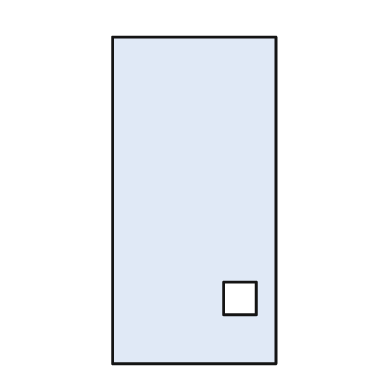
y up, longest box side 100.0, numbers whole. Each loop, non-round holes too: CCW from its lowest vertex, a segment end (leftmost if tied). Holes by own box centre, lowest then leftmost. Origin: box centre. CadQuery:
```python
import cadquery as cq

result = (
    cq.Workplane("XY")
    .moveTo(-25.0, -50.0)
    .lineTo(25.0, -50.0)
    .lineTo(25.0, 50.0)
    .lineTo(-25.0, 50.0)
    .close()
    .moveTo(9.0, -35.0)
    .lineTo(19.0, -35.0)
    .lineTo(19.0, -25.0)
    .lineTo(9.0, -25.0)
    .close()
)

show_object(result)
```